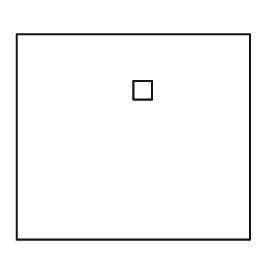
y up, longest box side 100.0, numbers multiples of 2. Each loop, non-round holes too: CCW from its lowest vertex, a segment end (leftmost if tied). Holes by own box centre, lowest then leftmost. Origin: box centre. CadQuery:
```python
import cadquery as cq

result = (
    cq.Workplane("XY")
    .moveTo(-50.0, -44.0)
    .lineTo(50.0, -44.0)
    .lineTo(50.0, 44.0)
    .lineTo(-50.0, 44.0)
    .close()
    .moveTo(0.0, 16.0)
    .lineTo(8.0, 16.0)
    .lineTo(8.0, 24.0)
    .lineTo(0.0, 24.0)
    .close()
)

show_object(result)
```